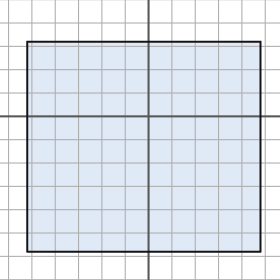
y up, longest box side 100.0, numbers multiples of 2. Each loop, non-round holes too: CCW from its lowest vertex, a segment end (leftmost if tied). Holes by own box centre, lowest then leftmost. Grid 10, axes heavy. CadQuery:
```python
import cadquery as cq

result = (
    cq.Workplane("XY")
    .moveTo(-52.0, -58.0)
    .lineTo(48.0, -58.0)
    .lineTo(48.0, 32.0)
    .lineTo(-52.0, 32.0)
    .close()
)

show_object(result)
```